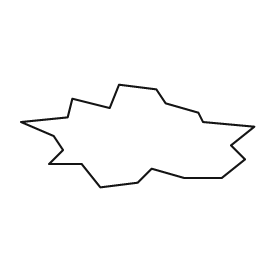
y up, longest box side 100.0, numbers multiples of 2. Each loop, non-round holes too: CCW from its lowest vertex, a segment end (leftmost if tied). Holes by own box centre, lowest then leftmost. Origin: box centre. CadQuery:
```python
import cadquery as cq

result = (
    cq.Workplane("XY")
    .moveTo(-16.0, -22.0)
    .lineTo(0.0, -20.0)
    .lineTo(6.0, -14.0)
    .lineTo(20.0, -18.0)
    .lineTo(36.0, -18.0)
    .lineTo(46.0, -10.0)
    .lineTo(40.0, -4.0)
    .lineTo(50.0, 4.0)
    .lineTo(28.0, 6.0)
    .lineTo(26.0, 10.0)
    .lineTo(12.0, 14.0)
    .lineTo(8.0, 20.0)
    .lineTo(-8.0, 22.0)
    .lineTo(-12.0, 12.0)
    .lineTo(-28.0, 16.0)
    .lineTo(-30.0, 8.0)
    .lineTo(-50.0, 6.0)
    .lineTo(-36.0, 0.0)
    .lineTo(-32.0, -6.0)
    .lineTo(-38.0, -12.0)
    .lineTo(-24.0, -12.0)
    .close()
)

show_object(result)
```